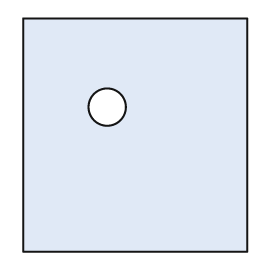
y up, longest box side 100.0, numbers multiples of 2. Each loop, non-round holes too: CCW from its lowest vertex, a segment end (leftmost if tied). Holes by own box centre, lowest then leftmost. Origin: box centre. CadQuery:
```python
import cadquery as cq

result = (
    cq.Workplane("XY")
    .moveTo(-48.0, -50.0)
    .lineTo(48.0, -50.0)
    .lineTo(48.0, 50.0)
    .lineTo(-48.0, 50.0)
    .close()
    .moveTo(-12.0, 12.0)
    .circle(8.0)
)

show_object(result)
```